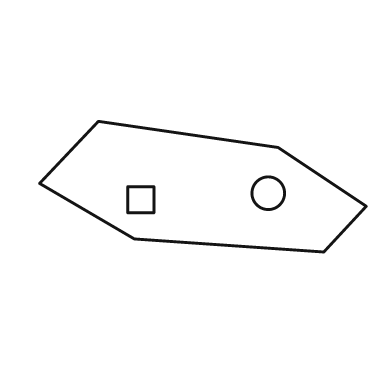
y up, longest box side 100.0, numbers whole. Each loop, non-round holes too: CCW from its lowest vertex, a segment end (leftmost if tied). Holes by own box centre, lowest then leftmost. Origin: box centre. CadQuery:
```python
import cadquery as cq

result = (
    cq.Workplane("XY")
    .moveTo(37.0, -20.0)
    .lineTo(50.0, -6.0)
    .lineTo(23.0, 12.0)
    .lineTo(-32.0, 20.0)
    .lineTo(-50.0, 1.0)
    .lineTo(-21.0, -16.0)
    .close()
    .moveTo(-23.0, -8.0)
    .lineTo(-15.0, -8.0)
    .lineTo(-15.0, 0.0)
    .lineTo(-23.0, 0.0)
    .close()
    .moveTo(20.0, -2.0)
    .circle(5.0)
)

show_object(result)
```